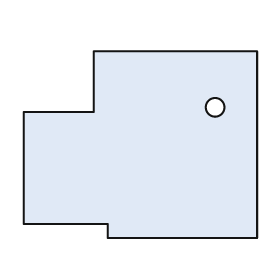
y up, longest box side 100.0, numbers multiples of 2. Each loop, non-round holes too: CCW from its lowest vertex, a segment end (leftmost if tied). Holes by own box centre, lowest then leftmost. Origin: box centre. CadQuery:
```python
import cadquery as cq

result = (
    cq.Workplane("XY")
    .moveTo(-14.0, -40.0)
    .lineTo(50.0, -40.0)
    .lineTo(50.0, 40.0)
    .lineTo(-20.0, 40.0)
    .lineTo(-20.0, 14.0)
    .lineTo(-50.0, 14.0)
    .lineTo(-50.0, -34.0)
    .lineTo(-14.0, -34.0)
    .close()
    .moveTo(32.0, 16.0)
    .circle(4.0)
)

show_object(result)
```